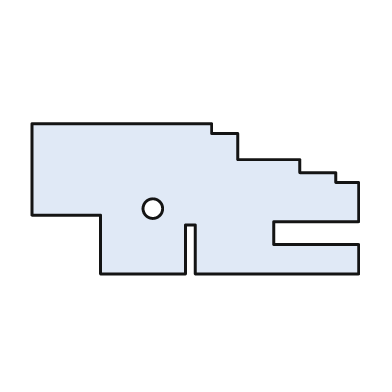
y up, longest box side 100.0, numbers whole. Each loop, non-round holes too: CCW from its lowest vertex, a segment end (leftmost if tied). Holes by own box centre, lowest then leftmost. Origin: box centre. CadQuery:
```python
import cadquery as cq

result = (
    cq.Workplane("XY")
    .moveTo(-29.0, -23.0)
    .lineTo(-3.0, -23.0)
    .lineTo(-3.0, -8.0)
    .lineTo(0.0, -8.0)
    .lineTo(0.0, -23.0)
    .lineTo(50.0, -23.0)
    .lineTo(50.0, -14.0)
    .lineTo(24.0, -14.0)
    .lineTo(24.0, -7.0)
    .lineTo(50.0, -7.0)
    .lineTo(50.0, 5.0)
    .lineTo(43.0, 5.0)
    .lineTo(43.0, 8.0)
    .lineTo(32.0, 8.0)
    .lineTo(32.0, 12.0)
    .lineTo(13.0, 12.0)
    .lineTo(13.0, 20.0)
    .lineTo(5.0, 20.0)
    .lineTo(5.0, 23.0)
    .lineTo(-50.0, 23.0)
    .lineTo(-50.0, -5.0)
    .lineTo(-29.0, -5.0)
    .close()
    .moveTo(-13.0, -3.0)
    .circle(3.0)
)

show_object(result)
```